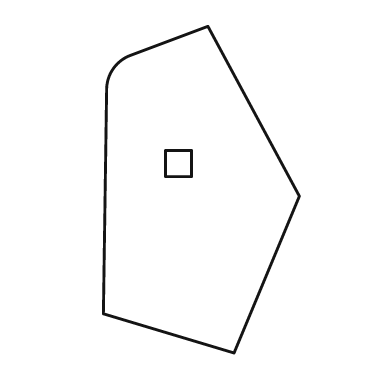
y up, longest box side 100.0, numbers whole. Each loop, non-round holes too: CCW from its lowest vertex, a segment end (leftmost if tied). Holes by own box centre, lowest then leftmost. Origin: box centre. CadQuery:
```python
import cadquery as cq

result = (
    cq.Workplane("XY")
    .moveTo(10.0, -50.0)
    .lineTo(30.0, -2.0)
    .lineTo(2.0, 50.0)
    .lineTo(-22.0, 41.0)
    .threePointArc((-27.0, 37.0), (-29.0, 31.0))
    .lineTo(-30.0, -38.0)
    .close()
    .moveTo(-11.0, 4.0)
    .lineTo(-3.0, 4.0)
    .lineTo(-3.0, 12.0)
    .lineTo(-11.0, 12.0)
    .close()
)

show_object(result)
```